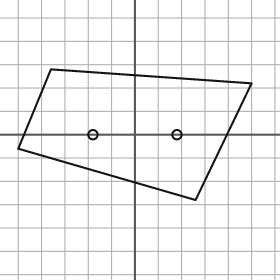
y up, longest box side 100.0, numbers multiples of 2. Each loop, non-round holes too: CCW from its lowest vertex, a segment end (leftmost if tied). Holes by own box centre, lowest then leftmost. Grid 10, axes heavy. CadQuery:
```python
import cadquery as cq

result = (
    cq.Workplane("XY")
    .moveTo(26.0, -28.0)
    .lineTo(50.0, 22.0)
    .lineTo(-36.0, 28.0)
    .lineTo(-50.0, -6.0)
    .close()
    .moveTo(-18.0, 0.0)
    .circle(2.0)
    .moveTo(18.0, 0.0)
    .circle(2.0)
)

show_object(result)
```